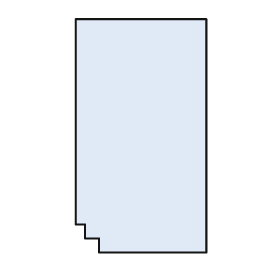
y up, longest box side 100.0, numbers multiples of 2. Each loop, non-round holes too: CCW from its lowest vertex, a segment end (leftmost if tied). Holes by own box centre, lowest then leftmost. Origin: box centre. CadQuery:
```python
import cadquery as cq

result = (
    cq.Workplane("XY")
    .moveTo(-18.0, -50.0)
    .lineTo(28.0, -50.0)
    .lineTo(28.0, 50.0)
    .lineTo(-28.0, 50.0)
    .lineTo(-28.0, -38.0)
    .lineTo(-24.0, -38.0)
    .lineTo(-24.0, -44.0)
    .lineTo(-18.0, -44.0)
    .close()
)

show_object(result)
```